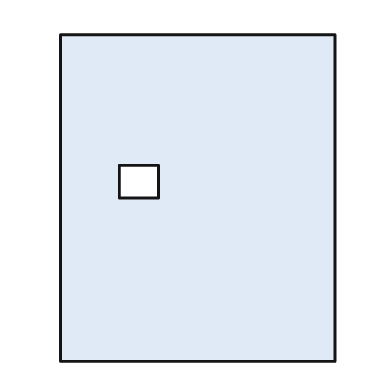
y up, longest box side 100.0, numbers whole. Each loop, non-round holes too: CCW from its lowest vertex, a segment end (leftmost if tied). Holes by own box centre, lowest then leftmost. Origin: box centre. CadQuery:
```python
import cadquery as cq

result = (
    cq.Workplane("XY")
    .moveTo(-42.0, -50.0)
    .lineTo(42.0, -50.0)
    .lineTo(42.0, 50.0)
    .lineTo(-42.0, 50.0)
    .close()
    .moveTo(-24.0, 0.0)
    .lineTo(-12.0, 0.0)
    .lineTo(-12.0, 10.0)
    .lineTo(-24.0, 10.0)
    .close()
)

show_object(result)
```